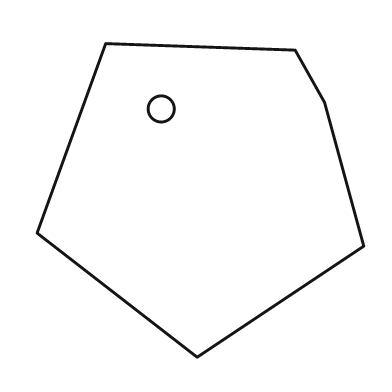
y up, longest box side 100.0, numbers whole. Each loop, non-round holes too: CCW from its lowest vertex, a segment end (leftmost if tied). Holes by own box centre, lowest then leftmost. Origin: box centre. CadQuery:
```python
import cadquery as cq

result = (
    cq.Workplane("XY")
    .moveTo(-1.0, -48.0)
    .lineTo(50.0, -14.0)
    .lineTo(38.0, 30.0)
    .lineTo(29.0, 46.0)
    .lineTo(-29.0, 48.0)
    .lineTo(-50.0, -10.0)
    .close()
    .moveTo(-12.0, 28.0)
    .circle(4.0)
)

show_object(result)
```